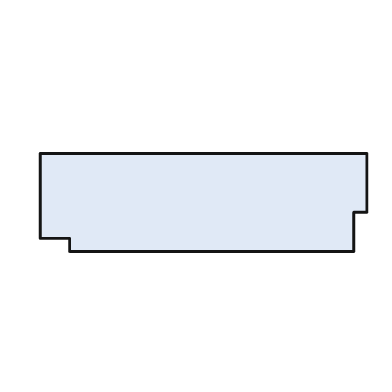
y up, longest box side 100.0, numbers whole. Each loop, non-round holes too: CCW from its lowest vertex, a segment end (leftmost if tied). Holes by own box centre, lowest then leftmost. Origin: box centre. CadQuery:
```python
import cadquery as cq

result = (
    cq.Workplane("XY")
    .moveTo(-41.0, -15.0)
    .lineTo(46.0, -15.0)
    .lineTo(46.0, -3.0)
    .lineTo(50.0, -3.0)
    .lineTo(50.0, 15.0)
    .lineTo(-50.0, 15.0)
    .lineTo(-50.0, -11.0)
    .lineTo(-41.0, -11.0)
    .close()
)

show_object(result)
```